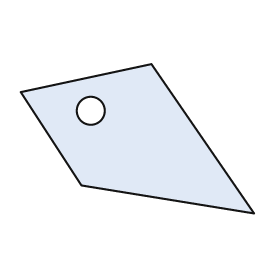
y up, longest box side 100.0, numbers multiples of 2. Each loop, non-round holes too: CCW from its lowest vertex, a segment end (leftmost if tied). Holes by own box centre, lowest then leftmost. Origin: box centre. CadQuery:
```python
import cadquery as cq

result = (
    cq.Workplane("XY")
    .moveTo(50.0, -32.0)
    .lineTo(6.0, 32.0)
    .lineTo(-50.0, 20.0)
    .lineTo(-24.0, -20.0)
    .close()
    .moveTo(-20.0, 12.0)
    .circle(6.0)
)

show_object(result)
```